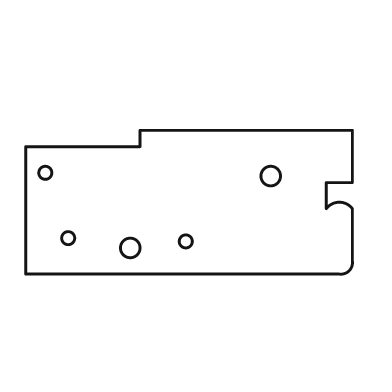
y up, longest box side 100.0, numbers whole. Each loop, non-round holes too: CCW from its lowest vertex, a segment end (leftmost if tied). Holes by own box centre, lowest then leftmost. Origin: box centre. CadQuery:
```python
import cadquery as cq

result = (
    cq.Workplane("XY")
    .moveTo(-50.0, -22.0)
    .lineTo(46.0, -22.0)
    .threePointArc((49.0, -21.0), (50.0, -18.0))
    .lineTo(50.0, -2.0)
    .threePointArc((46.0, 0.0), (42.0, -2.0))
    .lineTo(42.0, 6.0)
    .lineTo(50.0, 6.0)
    .lineTo(50.0, 22.0)
    .lineTo(-15.0, 22.0)
    .lineTo(-15.0, 17.0)
    .lineTo(-50.0, 17.0)
    .close()
    .moveTo(-18.0, -14.0)
    .circle(3.0)
    .moveTo(-1.0, -12.0)
    .circle(2.0)
    .moveTo(-37.0, -11.0)
    .circle(2.0)
    .moveTo(25.0, 8.0)
    .circle(3.0)
    .moveTo(-44.0, 9.0)
    .circle(2.0)
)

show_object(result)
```